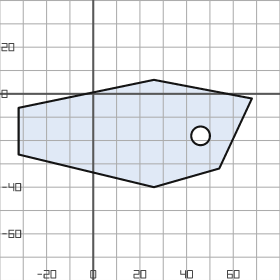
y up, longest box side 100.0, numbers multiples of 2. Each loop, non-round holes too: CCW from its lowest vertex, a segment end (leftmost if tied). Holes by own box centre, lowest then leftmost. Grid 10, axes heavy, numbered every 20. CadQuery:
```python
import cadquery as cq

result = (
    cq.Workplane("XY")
    .moveTo(26.0, -40.0)
    .lineTo(54.0, -32.0)
    .lineTo(68.0, -2.0)
    .lineTo(26.0, 6.0)
    .lineTo(-32.0, -6.0)
    .lineTo(-32.0, -26.0)
    .close()
    .moveTo(46.0, -18.0)
    .circle(4.0)
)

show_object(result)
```